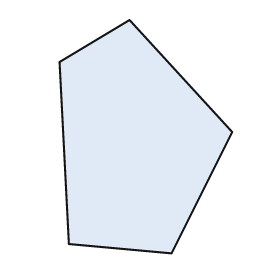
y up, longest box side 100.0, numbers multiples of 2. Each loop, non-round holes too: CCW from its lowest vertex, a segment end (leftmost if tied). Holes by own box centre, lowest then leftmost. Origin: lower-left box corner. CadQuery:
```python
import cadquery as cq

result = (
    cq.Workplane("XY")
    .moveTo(48.0, 0.0)
    .lineTo(74.0, 52.0)
    .lineTo(30.0, 100.0)
    .lineTo(0.0, 82.0)
    .lineTo(4.0, 4.0)
    .close()
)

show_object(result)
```